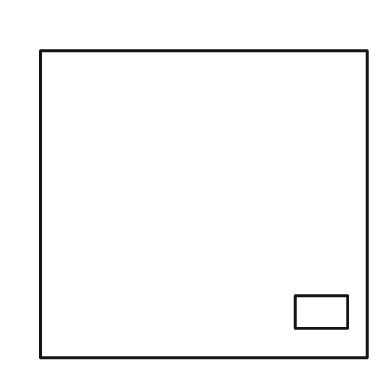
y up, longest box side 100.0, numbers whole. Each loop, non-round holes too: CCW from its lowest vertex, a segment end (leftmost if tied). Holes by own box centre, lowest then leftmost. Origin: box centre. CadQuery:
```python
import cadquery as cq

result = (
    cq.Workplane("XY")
    .moveTo(-50.0, -47.0)
    .lineTo(50.0, -47.0)
    .lineTo(50.0, 47.0)
    .lineTo(-50.0, 47.0)
    .close()
    .moveTo(28.0, -38.0)
    .lineTo(44.0, -38.0)
    .lineTo(44.0, -28.0)
    .lineTo(28.0, -28.0)
    .close()
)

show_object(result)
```